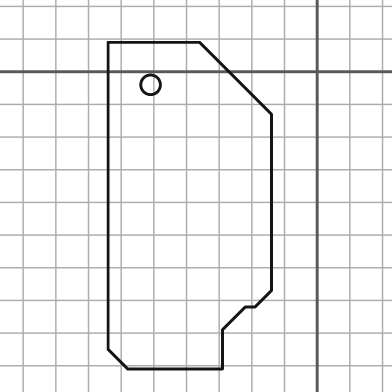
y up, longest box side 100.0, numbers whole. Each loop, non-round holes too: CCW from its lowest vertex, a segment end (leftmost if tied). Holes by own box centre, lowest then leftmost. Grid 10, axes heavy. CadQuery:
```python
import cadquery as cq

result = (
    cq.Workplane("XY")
    .moveTo(-58.0, -91.0)
    .lineTo(-29.0, -91.0)
    .lineTo(-29.0, -79.0)
    .lineTo(-22.0, -72.0)
    .lineTo(-19.0, -72.0)
    .lineTo(-14.0, -67.0)
    .lineTo(-14.0, -13.0)
    .lineTo(-36.0, 9.0)
    .lineTo(-64.0, 9.0)
    .lineTo(-64.0, -85.0)
    .close()
    .moveTo(-51.0, -4.0)
    .circle(3.0)
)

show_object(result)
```